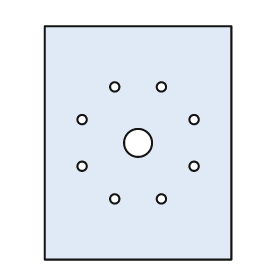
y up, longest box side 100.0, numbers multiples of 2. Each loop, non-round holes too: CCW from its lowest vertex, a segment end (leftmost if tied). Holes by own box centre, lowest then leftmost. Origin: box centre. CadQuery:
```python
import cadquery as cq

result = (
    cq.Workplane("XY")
    .moveTo(-40.0, -50.0)
    .lineTo(40.0, -50.0)
    .lineTo(40.0, 50.0)
    .lineTo(-40.0, 50.0)
    .close()
    .moveTo(-10.0, -24.0)
    .circle(2.0)
    .moveTo(10.0, -24.0)
    .circle(2.0)
    .moveTo(-24.0, -10.0)
    .circle(2.0)
    .moveTo(24.0, -10.0)
    .circle(2.0)
    .moveTo(0.0, 0.0)
    .circle(6.0)
    .moveTo(-24.0, 10.0)
    .circle(2.0)
    .moveTo(24.0, 10.0)
    .circle(2.0)
    .moveTo(-10.0, 24.0)
    .circle(2.0)
    .moveTo(10.0, 24.0)
    .circle(2.0)
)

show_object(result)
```